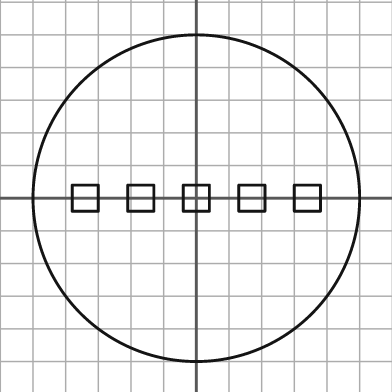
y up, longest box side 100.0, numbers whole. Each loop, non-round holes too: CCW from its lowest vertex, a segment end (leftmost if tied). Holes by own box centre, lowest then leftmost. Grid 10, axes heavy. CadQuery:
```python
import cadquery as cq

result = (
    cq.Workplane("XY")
    .moveTo(0.0, 0.0)
    .circle(50.0)
    .moveTo(-38.0, -4.0)
    .lineTo(-30.0, -4.0)
    .lineTo(-30.0, 4.0)
    .lineTo(-38.0, 4.0)
    .close()
    .moveTo(-21.0, -4.0)
    .lineTo(-13.0, -4.0)
    .lineTo(-13.0, 4.0)
    .lineTo(-21.0, 4.0)
    .close()
    .moveTo(-4.0, -4.0)
    .lineTo(4.0, -4.0)
    .lineTo(4.0, 4.0)
    .lineTo(-4.0, 4.0)
    .close()
    .moveTo(13.0, -4.0)
    .lineTo(21.0, -4.0)
    .lineTo(21.0, 4.0)
    .lineTo(13.0, 4.0)
    .close()
    .moveTo(30.0, -4.0)
    .lineTo(38.0, -4.0)
    .lineTo(38.0, 4.0)
    .lineTo(30.0, 4.0)
    .close()
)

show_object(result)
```